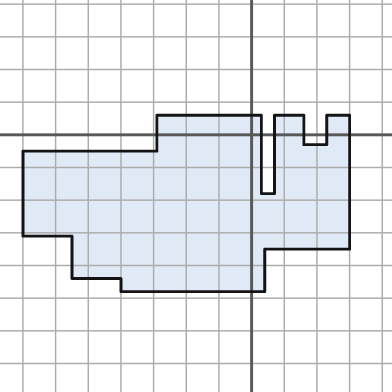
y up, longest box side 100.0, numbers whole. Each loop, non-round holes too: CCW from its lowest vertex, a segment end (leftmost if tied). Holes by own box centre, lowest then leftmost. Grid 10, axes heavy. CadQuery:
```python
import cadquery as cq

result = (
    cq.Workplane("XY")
    .moveTo(-40.0, -48.0)
    .lineTo(4.0, -48.0)
    .lineTo(4.0, -35.0)
    .lineTo(30.0, -35.0)
    .lineTo(30.0, 6.0)
    .lineTo(23.0, 6.0)
    .lineTo(23.0, -3.0)
    .lineTo(16.0, -3.0)
    .lineTo(16.0, 6.0)
    .lineTo(7.0, 6.0)
    .lineTo(7.0, -18.0)
    .lineTo(3.0, -18.0)
    .lineTo(3.0, 6.0)
    .lineTo(-29.0, 6.0)
    .lineTo(-29.0, -5.0)
    .lineTo(-70.0, -5.0)
    .lineTo(-70.0, -31.0)
    .lineTo(-55.0, -31.0)
    .lineTo(-55.0, -44.0)
    .lineTo(-40.0, -44.0)
    .close()
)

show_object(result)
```